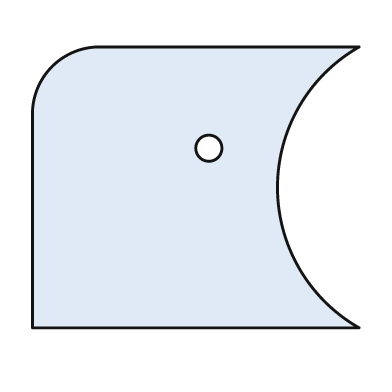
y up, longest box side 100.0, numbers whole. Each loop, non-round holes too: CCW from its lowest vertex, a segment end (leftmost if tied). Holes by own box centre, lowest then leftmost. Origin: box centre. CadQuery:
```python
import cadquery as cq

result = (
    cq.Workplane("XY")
    .moveTo(-50.0, -43.0)
    .lineTo(50.0, -43.0)
    .threePointArc((25.0, 0.0), (50.0, 43.0))
    .lineTo(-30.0, 43.0)
    .threePointArc((-44.0, 37.0), (-50.0, 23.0))
    .close()
    .moveTo(4.0, 12.0)
    .circle(4.0)
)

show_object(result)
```